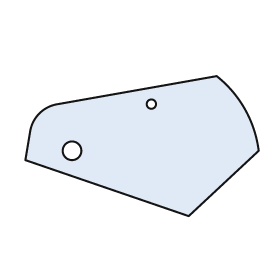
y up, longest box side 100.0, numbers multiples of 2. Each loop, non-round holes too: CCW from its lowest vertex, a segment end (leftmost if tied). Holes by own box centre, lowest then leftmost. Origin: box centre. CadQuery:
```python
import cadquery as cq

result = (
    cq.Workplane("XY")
    .moveTo(20.0, -30.0)
    .lineTo(50.0, -2.0)
    .threePointArc((44.0, 16.0), (32.0, 30.0))
    .lineTo(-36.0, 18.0)
    .threePointArc((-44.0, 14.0), (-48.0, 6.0))
    .lineTo(-50.0, -6.0)
    .close()
    .moveTo(-30.0, -2.0)
    .circle(4.0)
    .moveTo(4.0, 18.0)
    .circle(2.0)
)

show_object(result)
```